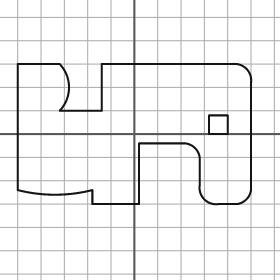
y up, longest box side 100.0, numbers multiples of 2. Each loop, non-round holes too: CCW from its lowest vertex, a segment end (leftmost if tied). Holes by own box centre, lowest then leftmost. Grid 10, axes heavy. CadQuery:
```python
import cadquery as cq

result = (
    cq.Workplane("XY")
    .moveTo(-18.0, -30.0)
    .lineTo(2.0, -30.0)
    .lineTo(2.0, -4.0)
    .lineTo(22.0, -4.0)
    .threePointArc((26.0, -6.0), (28.0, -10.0))
    .lineTo(28.0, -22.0)
    .threePointArc((30.0, -28.0), (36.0, -30.0))
    .lineTo(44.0, -30.0)
    .threePointArc((48.0, -28.0), (50.0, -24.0))
    .lineTo(50.0, 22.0)
    .threePointArc((48.0, 28.0), (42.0, 30.0))
    .lineTo(-14.0, 30.0)
    .lineTo(-14.0, 10.0)
    .lineTo(-32.0, 10.0)
    .threePointArc((-28.0, 20.0), (-32.0, 30.0))
    .lineTo(-50.0, 30.0)
    .lineTo(-50.0, -24.0)
    .threePointArc((-34.0, -26.0), (-18.0, -24.0))
    .close()
    .moveTo(32.0, 0.0)
    .lineTo(40.0, 0.0)
    .lineTo(40.0, 8.0)
    .lineTo(32.0, 8.0)
    .close()
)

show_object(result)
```